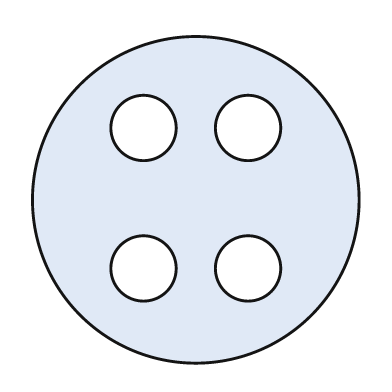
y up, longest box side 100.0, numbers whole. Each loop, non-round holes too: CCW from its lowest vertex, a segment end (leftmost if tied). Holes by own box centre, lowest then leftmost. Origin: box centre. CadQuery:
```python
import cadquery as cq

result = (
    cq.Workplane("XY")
    .moveTo(0.0, 0.0)
    .circle(50.0)
    .moveTo(-16.0, -21.0)
    .circle(10.0)
    .moveTo(16.0, -21.0)
    .circle(10.0)
    .moveTo(-16.0, 22.0)
    .circle(10.0)
    .moveTo(16.0, 22.0)
    .circle(10.0)
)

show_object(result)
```